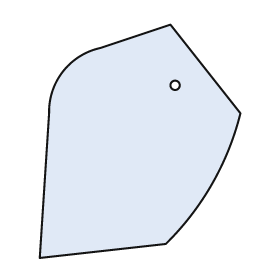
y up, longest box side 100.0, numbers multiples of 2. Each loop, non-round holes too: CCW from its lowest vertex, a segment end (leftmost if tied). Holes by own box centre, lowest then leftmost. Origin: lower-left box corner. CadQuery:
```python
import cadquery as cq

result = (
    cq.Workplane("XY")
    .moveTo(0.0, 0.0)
    .lineTo(54.0, 6.0)
    .threePointArc((74.0, 32.0), (86.0, 62.0))
    .lineTo(56.0, 100.0)
    .lineTo(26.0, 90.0)
    .threePointArc((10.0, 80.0), (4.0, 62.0))
    .close()
    .moveTo(58.0, 74.0)
    .circle(2.0)
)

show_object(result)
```